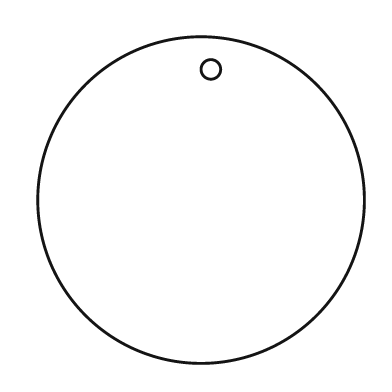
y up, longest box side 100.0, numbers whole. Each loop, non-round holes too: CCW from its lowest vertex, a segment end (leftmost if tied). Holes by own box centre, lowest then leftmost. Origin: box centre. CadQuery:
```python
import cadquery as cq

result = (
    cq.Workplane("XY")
    .moveTo(0.0, 0.0)
    .circle(50.0)
    .moveTo(3.0, 40.0)
    .circle(3.0)
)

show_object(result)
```